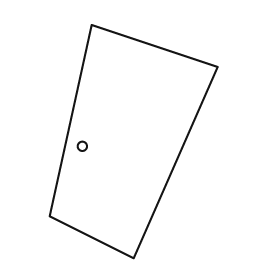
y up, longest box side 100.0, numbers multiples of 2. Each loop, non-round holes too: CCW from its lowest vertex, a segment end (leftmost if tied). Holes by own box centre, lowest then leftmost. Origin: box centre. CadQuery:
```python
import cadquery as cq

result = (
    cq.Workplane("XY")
    .moveTo(0.0, -50.0)
    .lineTo(36.0, 32.0)
    .lineTo(-18.0, 50.0)
    .lineTo(-36.0, -32.0)
    .close()
    .moveTo(-22.0, -2.0)
    .circle(2.0)
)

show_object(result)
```